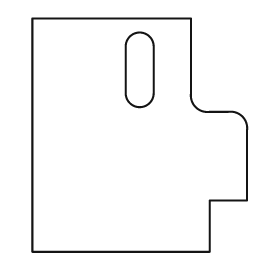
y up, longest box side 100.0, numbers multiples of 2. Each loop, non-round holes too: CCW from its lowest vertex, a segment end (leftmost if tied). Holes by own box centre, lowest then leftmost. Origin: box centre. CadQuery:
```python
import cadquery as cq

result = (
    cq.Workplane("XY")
    .moveTo(-46.0, -50.0)
    .lineTo(30.0, -50.0)
    .lineTo(30.0, -28.0)
    .lineTo(46.0, -28.0)
    .lineTo(46.0, 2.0)
    .threePointArc((44.0, 8.0), (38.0, 10.0))
    .lineTo(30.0, 10.0)
    .threePointArc((24.0, 12.0), (22.0, 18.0))
    .lineTo(22.0, 50.0)
    .lineTo(-46.0, 50.0)
    .close()
    .moveTo(-6.0, 18.0)
    .threePointArc((0.0, 12.0), (6.0, 18.0))
    .lineTo(6.0, 38.0)
    .threePointArc((0.0, 44.0), (-6.0, 38.0))
    .close()
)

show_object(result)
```